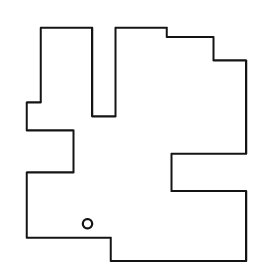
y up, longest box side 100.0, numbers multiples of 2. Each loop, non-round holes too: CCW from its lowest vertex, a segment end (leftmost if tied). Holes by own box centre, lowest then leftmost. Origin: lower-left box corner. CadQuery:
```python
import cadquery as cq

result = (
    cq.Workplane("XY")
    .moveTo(36.0, 0.0)
    .lineTo(94.0, 0.0)
    .lineTo(94.0, 30.0)
    .lineTo(62.0, 30.0)
    .lineTo(62.0, 46.0)
    .lineTo(94.0, 46.0)
    .lineTo(94.0, 86.0)
    .lineTo(80.0, 86.0)
    .lineTo(80.0, 96.0)
    .lineTo(60.0, 96.0)
    .lineTo(60.0, 100.0)
    .lineTo(38.0, 100.0)
    .lineTo(38.0, 62.0)
    .lineTo(28.0, 62.0)
    .lineTo(28.0, 100.0)
    .lineTo(6.0, 100.0)
    .lineTo(6.0, 68.0)
    .lineTo(0.0, 68.0)
    .lineTo(0.0, 56.0)
    .lineTo(20.0, 56.0)
    .lineTo(20.0, 38.0)
    .lineTo(0.0, 38.0)
    .lineTo(0.0, 10.0)
    .lineTo(36.0, 10.0)
    .close()
    .moveTo(26.0, 16.0)
    .circle(2.0)
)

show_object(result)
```